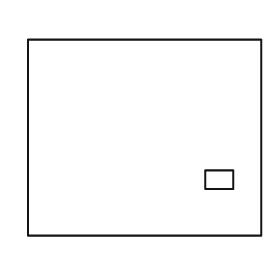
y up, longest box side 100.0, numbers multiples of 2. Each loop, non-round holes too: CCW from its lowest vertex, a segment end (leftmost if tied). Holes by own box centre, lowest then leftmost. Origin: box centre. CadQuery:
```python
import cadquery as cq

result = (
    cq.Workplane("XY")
    .moveTo(-50.0, -42.0)
    .lineTo(50.0, -42.0)
    .lineTo(50.0, 42.0)
    .lineTo(-50.0, 42.0)
    .close()
    .moveTo(26.0, -22.0)
    .lineTo(38.0, -22.0)
    .lineTo(38.0, -14.0)
    .lineTo(26.0, -14.0)
    .close()
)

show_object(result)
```